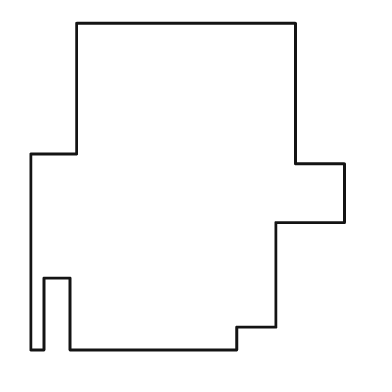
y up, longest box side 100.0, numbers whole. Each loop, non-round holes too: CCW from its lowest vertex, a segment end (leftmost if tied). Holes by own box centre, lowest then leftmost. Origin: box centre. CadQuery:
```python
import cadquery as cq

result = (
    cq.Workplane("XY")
    .moveTo(-48.0, -50.0)
    .lineTo(-44.0, -50.0)
    .lineTo(-44.0, -28.0)
    .lineTo(-36.0, -28.0)
    .lineTo(-36.0, -50.0)
    .lineTo(15.0, -50.0)
    .lineTo(15.0, -43.0)
    .lineTo(27.0, -43.0)
    .lineTo(27.0, -11.0)
    .lineTo(48.0, -11.0)
    .lineTo(48.0, 7.0)
    .lineTo(33.0, 7.0)
    .lineTo(33.0, 50.0)
    .lineTo(-34.0, 50.0)
    .lineTo(-34.0, 10.0)
    .lineTo(-48.0, 10.0)
    .close()
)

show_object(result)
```